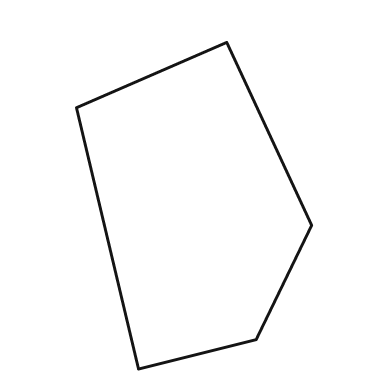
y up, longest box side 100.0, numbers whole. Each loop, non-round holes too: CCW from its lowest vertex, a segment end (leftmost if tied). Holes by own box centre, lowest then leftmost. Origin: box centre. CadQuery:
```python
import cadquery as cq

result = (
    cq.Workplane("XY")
    .moveTo(-17.0, -50.0)
    .lineTo(19.0, -41.0)
    .lineTo(36.0, -6.0)
    .lineTo(10.0, 50.0)
    .lineTo(-36.0, 30.0)
    .close()
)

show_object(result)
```